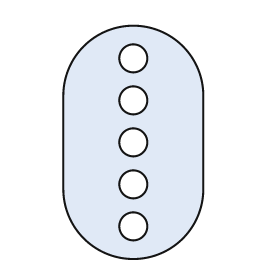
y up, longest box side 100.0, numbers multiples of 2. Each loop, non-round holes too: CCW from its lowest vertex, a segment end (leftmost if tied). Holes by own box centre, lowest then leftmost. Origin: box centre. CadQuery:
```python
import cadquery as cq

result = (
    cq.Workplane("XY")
    .moveTo(-30.0, -20.0)
    .threePointArc((0.0, -50.0), (30.0, -20.0))
    .lineTo(30.0, 20.0)
    .threePointArc((0.0, 50.0), (-30.0, 20.0))
    .close()
    .moveTo(0.0, -36.0)
    .circle(6.0)
    .moveTo(0.0, -18.0)
    .circle(6.0)
    .moveTo(0.0, 0.0)
    .circle(6.0)
    .moveTo(0.0, 18.0)
    .circle(6.0)
    .moveTo(0.0, 36.0)
    .circle(6.0)
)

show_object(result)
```